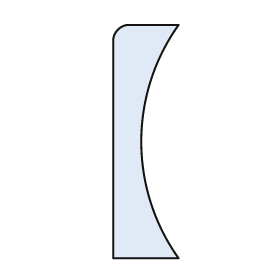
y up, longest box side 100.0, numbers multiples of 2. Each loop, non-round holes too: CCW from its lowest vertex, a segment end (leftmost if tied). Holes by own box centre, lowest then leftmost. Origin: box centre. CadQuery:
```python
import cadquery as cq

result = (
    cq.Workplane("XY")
    .moveTo(-14.0, -50.0)
    .lineTo(14.0, -50.0)
    .threePointArc((-2.0, 0.0), (14.0, 50.0))
    .lineTo(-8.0, 50.0)
    .threePointArc((-12.0, 48.0), (-14.0, 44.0))
    .close()
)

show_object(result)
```